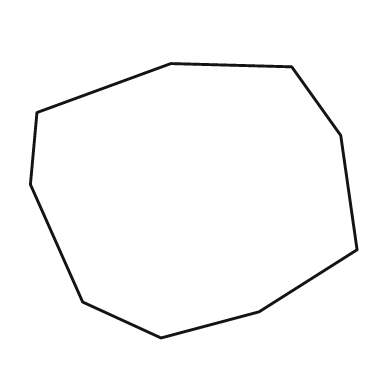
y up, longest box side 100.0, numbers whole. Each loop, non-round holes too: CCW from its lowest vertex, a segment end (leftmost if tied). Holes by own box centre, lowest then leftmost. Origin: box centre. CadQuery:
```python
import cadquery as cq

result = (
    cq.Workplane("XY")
    .moveTo(-10.0, -42.0)
    .lineTo(20.0, -34.0)
    .lineTo(50.0, -15.0)
    .lineTo(45.0, 20.0)
    .lineTo(30.0, 41.0)
    .lineTo(-7.0, 42.0)
    .lineTo(-48.0, 27.0)
    .lineTo(-50.0, 5.0)
    .lineTo(-34.0, -31.0)
    .close()
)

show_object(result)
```